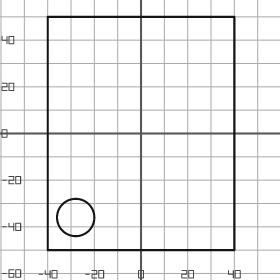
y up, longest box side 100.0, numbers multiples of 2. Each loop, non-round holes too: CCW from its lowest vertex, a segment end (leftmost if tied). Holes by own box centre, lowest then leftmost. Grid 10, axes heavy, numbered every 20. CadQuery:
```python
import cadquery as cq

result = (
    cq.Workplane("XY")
    .moveTo(-40.0, -50.0)
    .lineTo(40.0, -50.0)
    .lineTo(40.0, 50.0)
    .lineTo(-40.0, 50.0)
    .close()
    .moveTo(-28.0, -36.0)
    .circle(8.0)
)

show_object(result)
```